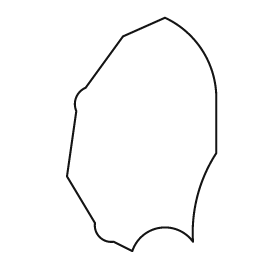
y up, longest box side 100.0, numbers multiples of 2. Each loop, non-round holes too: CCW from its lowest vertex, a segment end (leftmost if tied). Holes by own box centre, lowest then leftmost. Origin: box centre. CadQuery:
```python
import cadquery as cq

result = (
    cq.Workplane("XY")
    .moveTo(-4.0, -50.0)
    .threePointArc((8.0, -40.0), (22.0, -46.0))
    .threePointArc((24.0, -26.0), (32.0, -8.0))
    .lineTo(32.0, 16.0)
    .threePointArc((26.0, 36.0), (10.0, 50.0))
    .lineTo(-8.0, 42.0)
    .lineTo(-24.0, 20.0)
    .threePointArc((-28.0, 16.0), (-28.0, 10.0))
    .lineTo(-32.0, -18.0)
    .lineTo(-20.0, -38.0)
    .threePointArc((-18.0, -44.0), (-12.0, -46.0))
    .close()
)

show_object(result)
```